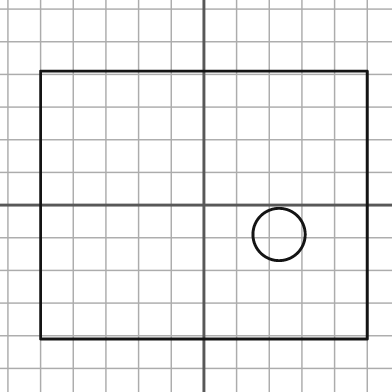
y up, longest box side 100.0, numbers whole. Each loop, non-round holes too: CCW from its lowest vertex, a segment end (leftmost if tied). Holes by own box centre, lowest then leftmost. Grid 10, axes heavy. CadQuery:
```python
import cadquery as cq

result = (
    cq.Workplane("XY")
    .moveTo(-50.0, -41.0)
    .lineTo(50.0, -41.0)
    .lineTo(50.0, 41.0)
    .lineTo(-50.0, 41.0)
    .close()
    .moveTo(23.0, -9.0)
    .circle(8.0)
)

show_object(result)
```